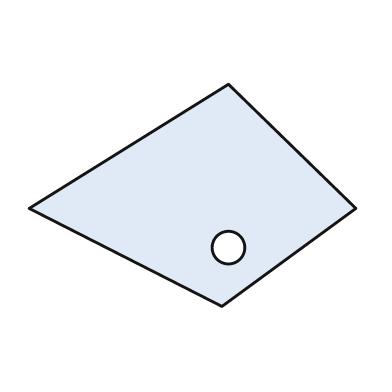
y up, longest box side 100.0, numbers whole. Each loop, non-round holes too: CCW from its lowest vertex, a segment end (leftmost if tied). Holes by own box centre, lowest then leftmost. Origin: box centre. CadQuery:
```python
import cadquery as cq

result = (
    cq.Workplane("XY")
    .moveTo(9.0, -34.0)
    .lineTo(50.0, -4.0)
    .lineTo(11.0, 34.0)
    .lineTo(-50.0, -4.0)
    .close()
    .moveTo(11.0, -16.0)
    .circle(5.0)
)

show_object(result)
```